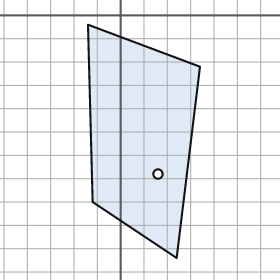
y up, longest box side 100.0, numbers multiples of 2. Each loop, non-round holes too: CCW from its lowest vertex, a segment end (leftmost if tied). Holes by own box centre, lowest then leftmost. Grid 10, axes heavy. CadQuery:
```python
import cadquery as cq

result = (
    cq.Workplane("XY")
    .moveTo(24.0, -104.0)
    .lineTo(34.0, -22.0)
    .lineTo(-14.0, -4.0)
    .lineTo(-12.0, -80.0)
    .close()
    .moveTo(16.0, -68.0)
    .circle(2.0)
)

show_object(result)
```